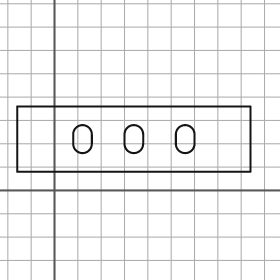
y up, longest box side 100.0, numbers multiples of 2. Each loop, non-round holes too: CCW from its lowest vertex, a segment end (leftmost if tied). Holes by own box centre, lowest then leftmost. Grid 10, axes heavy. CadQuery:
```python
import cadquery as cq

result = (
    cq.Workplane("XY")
    .moveTo(-16.0, 8.0)
    .lineTo(84.0, 8.0)
    .lineTo(84.0, 36.0)
    .lineTo(-16.0, 36.0)
    .close()
    .moveTo(8.0, 20.0)
    .threePointArc((12.0, 16.0), (16.0, 20.0))
    .lineTo(16.0, 24.0)
    .threePointArc((12.0, 28.0), (8.0, 24.0))
    .close()
    .moveTo(30.0, 20.0)
    .threePointArc((34.0, 16.0), (38.0, 20.0))
    .lineTo(38.0, 24.0)
    .threePointArc((34.0, 28.0), (30.0, 24.0))
    .close()
    .moveTo(52.0, 20.0)
    .threePointArc((56.0, 16.0), (60.0, 20.0))
    .lineTo(60.0, 24.0)
    .threePointArc((56.0, 28.0), (52.0, 24.0))
    .close()
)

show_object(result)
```